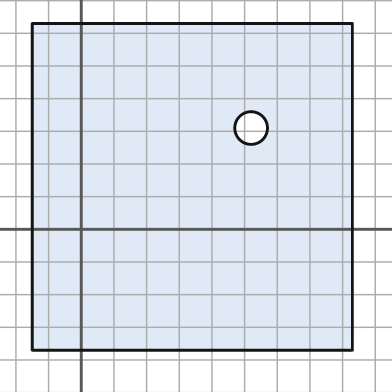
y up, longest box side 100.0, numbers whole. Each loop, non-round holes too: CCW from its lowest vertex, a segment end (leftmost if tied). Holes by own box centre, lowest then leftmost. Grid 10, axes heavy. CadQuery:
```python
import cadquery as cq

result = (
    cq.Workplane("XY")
    .moveTo(-15.0, -37.0)
    .lineTo(83.0, -37.0)
    .lineTo(83.0, 63.0)
    .lineTo(-15.0, 63.0)
    .close()
    .moveTo(52.0, 31.0)
    .circle(5.0)
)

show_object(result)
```